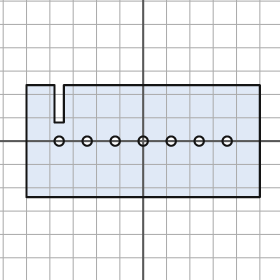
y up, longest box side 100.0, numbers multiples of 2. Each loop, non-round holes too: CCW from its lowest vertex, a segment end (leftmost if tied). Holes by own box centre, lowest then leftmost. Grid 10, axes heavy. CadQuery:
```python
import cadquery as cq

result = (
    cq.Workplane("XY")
    .moveTo(-50.0, -24.0)
    .lineTo(50.0, -24.0)
    .lineTo(50.0, 24.0)
    .lineTo(-34.0, 24.0)
    .lineTo(-34.0, 8.0)
    .lineTo(-38.0, 8.0)
    .lineTo(-38.0, 24.0)
    .lineTo(-50.0, 24.0)
    .close()
    .moveTo(-36.0, 0.0)
    .circle(2.0)
    .moveTo(-24.0, 0.0)
    .circle(2.0)
    .moveTo(-12.0, 0.0)
    .circle(2.0)
    .moveTo(0.0, 0.0)
    .circle(2.0)
    .moveTo(12.0, 0.0)
    .circle(2.0)
    .moveTo(24.0, 0.0)
    .circle(2.0)
    .moveTo(36.0, 0.0)
    .circle(2.0)
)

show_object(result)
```